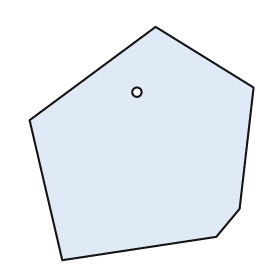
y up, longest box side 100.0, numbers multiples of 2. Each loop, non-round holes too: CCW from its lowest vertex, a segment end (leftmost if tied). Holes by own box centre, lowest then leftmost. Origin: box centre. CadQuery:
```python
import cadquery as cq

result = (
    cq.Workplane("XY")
    .moveTo(-34.0, -50.0)
    .lineTo(32.0, -40.0)
    .lineTo(42.0, -28.0)
    .lineTo(48.0, 24.0)
    .lineTo(6.0, 50.0)
    .lineTo(-48.0, 10.0)
    .close()
    .moveTo(-2.0, 22.0)
    .circle(2.0)
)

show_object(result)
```